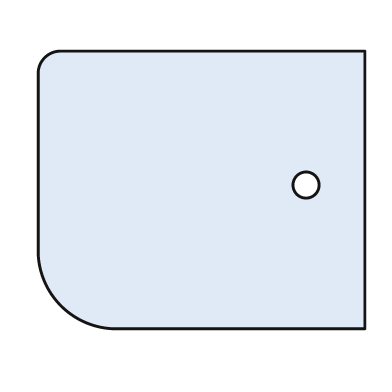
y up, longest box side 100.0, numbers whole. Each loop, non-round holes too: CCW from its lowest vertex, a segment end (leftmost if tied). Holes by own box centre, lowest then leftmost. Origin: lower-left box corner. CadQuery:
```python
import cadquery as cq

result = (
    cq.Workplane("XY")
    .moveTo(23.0, 0.0)
    .lineTo(100.0, 0.0)
    .lineTo(100.0, 85.0)
    .lineTo(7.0, 85.0)
    .threePointArc((2.0, 83.0), (0.0, 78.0))
    .lineTo(0.0, 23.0)
    .threePointArc((7.0, 7.0), (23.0, 0.0))
    .close()
    .moveTo(82.0, 44.0)
    .circle(4.0)
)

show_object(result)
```